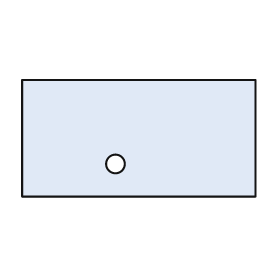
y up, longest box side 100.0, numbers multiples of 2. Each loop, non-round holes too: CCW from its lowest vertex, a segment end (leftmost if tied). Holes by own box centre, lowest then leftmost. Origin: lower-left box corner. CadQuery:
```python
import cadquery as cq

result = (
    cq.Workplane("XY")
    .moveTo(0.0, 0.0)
    .lineTo(100.0, 0.0)
    .lineTo(100.0, 50.0)
    .lineTo(0.0, 50.0)
    .close()
    .moveTo(40.0, 14.0)
    .circle(4.0)
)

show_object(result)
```